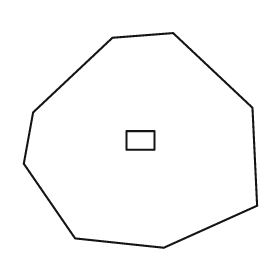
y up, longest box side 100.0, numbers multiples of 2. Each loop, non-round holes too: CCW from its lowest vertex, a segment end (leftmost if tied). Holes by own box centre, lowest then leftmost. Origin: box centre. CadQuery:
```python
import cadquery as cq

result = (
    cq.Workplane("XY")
    .moveTo(10.0, -46.0)
    .lineTo(50.0, -28.0)
    .lineTo(48.0, 14.0)
    .lineTo(14.0, 46.0)
    .lineTo(-12.0, 44.0)
    .lineTo(-46.0, 12.0)
    .lineTo(-50.0, -10.0)
    .lineTo(-28.0, -42.0)
    .close()
    .moveTo(-6.0, -4.0)
    .lineTo(6.0, -4.0)
    .lineTo(6.0, 4.0)
    .lineTo(-6.0, 4.0)
    .close()
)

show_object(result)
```